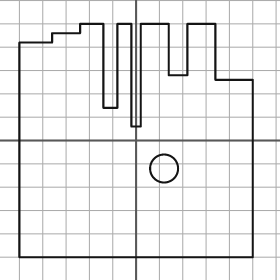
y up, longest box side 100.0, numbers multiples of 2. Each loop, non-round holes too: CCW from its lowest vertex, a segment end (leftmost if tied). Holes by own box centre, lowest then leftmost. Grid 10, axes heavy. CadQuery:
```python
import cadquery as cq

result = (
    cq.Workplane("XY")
    .moveTo(-50.0, -50.0)
    .lineTo(50.0, -50.0)
    .lineTo(50.0, 26.0)
    .lineTo(34.0, 26.0)
    .lineTo(34.0, 50.0)
    .lineTo(22.0, 50.0)
    .lineTo(22.0, 28.0)
    .lineTo(14.0, 28.0)
    .lineTo(14.0, 50.0)
    .lineTo(2.0, 50.0)
    .lineTo(2.0, 6.0)
    .lineTo(-2.0, 6.0)
    .lineTo(-2.0, 50.0)
    .lineTo(-8.0, 50.0)
    .lineTo(-8.0, 14.0)
    .lineTo(-14.0, 14.0)
    .lineTo(-14.0, 50.0)
    .lineTo(-24.0, 50.0)
    .lineTo(-24.0, 46.0)
    .lineTo(-36.0, 46.0)
    .lineTo(-36.0, 42.0)
    .lineTo(-50.0, 42.0)
    .close()
    .moveTo(12.0, -12.0)
    .circle(6.0)
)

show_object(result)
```